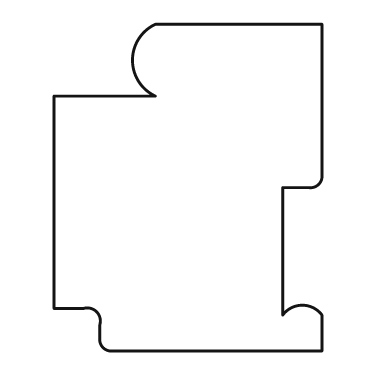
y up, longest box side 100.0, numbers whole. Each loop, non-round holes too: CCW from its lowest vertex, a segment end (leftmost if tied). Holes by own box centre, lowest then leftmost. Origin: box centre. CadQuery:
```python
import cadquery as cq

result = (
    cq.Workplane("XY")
    .moveTo(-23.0, -50.0)
    .lineTo(41.0, -50.0)
    .lineTo(41.0, -39.0)
    .threePointArc((35.0, -36.0), (29.0, -39.0))
    .lineTo(29.0, 0.0)
    .lineTo(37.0, 0.0)
    .threePointArc((40.0, 1.0), (41.0, 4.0))
    .lineTo(41.0, 50.0)
    .lineTo(-10.0, 50.0)
    .threePointArc((-17.0, 39.0), (-10.0, 28.0))
    .lineTo(-41.0, 28.0)
    .lineTo(-41.0, -37.0)
    .lineTo(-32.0, -37.0)
    .threePointArc((-28.0, -38.0), (-27.0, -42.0))
    .lineTo(-27.0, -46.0)
    .threePointArc((-26.0, -49.0), (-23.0, -50.0))
    .close()
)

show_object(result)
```